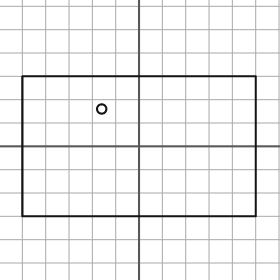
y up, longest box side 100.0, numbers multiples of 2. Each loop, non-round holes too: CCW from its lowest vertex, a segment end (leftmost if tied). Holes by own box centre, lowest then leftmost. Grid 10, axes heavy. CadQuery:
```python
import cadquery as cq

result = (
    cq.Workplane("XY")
    .moveTo(-50.0, -30.0)
    .lineTo(50.0, -30.0)
    .lineTo(50.0, 30.0)
    .lineTo(-50.0, 30.0)
    .close()
    .moveTo(-16.0, 16.0)
    .circle(2.0)
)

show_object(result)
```